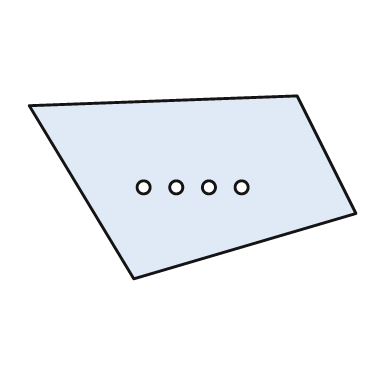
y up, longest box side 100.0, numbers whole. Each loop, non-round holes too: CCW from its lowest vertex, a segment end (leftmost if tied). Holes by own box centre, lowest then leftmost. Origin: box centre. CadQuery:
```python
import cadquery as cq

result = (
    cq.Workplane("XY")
    .moveTo(-18.0, -28.0)
    .lineTo(50.0, -8.0)
    .lineTo(32.0, 28.0)
    .lineTo(-50.0, 25.0)
    .close()
    .moveTo(-15.0, 0.0)
    .circle(2.0)
    .moveTo(-5.0, 0.0)
    .circle(2.0)
    .moveTo(5.0, 0.0)
    .circle(2.0)
    .moveTo(15.0, 0.0)
    .circle(2.0)
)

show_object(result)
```